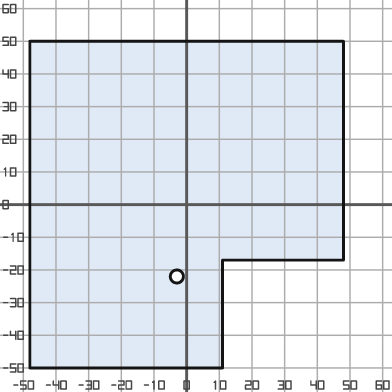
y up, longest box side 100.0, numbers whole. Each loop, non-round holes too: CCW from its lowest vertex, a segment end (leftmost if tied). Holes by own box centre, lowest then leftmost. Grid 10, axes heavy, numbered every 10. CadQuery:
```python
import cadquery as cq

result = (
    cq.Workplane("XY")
    .moveTo(-48.0, -50.0)
    .lineTo(11.0, -50.0)
    .lineTo(11.0, -17.0)
    .lineTo(48.0, -17.0)
    .lineTo(48.0, 50.0)
    .lineTo(-48.0, 50.0)
    .close()
    .moveTo(-3.0, -22.0)
    .circle(2.0)
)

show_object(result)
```